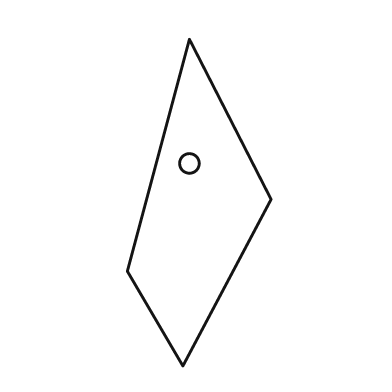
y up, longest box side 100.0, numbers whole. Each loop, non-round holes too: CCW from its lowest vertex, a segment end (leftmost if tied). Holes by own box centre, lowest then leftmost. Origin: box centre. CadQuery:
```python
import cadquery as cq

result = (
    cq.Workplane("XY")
    .moveTo(-5.0, -50.0)
    .lineTo(22.0, 1.0)
    .lineTo(-3.0, 50.0)
    .lineTo(-22.0, -21.0)
    .close()
    .moveTo(-3.0, 12.0)
    .circle(3.0)
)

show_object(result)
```